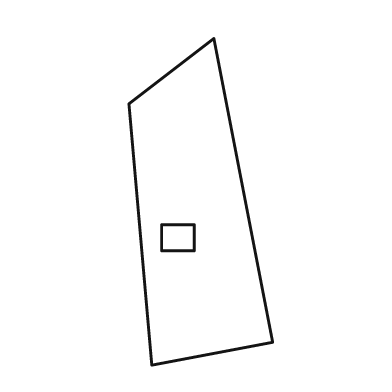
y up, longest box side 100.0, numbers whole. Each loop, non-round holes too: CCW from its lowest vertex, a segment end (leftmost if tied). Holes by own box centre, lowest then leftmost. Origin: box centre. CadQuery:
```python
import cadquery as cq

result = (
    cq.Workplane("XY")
    .moveTo(-15.0, -50.0)
    .lineTo(22.0, -43.0)
    .lineTo(4.0, 50.0)
    .lineTo(-22.0, 30.0)
    .close()
    .moveTo(-12.0, -15.0)
    .lineTo(-2.0, -15.0)
    .lineTo(-2.0, -7.0)
    .lineTo(-12.0, -7.0)
    .close()
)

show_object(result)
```